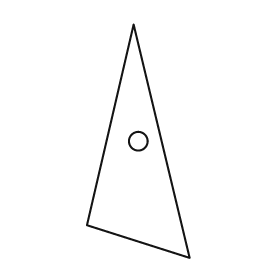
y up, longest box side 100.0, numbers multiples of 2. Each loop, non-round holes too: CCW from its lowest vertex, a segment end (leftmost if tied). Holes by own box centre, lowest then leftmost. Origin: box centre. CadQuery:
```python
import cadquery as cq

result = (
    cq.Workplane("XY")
    .moveTo(22.0, -50.0)
    .lineTo(-2.0, 50.0)
    .lineTo(-22.0, -36.0)
    .close()
    .moveTo(0.0, 0.0)
    .circle(4.0)
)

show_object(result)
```